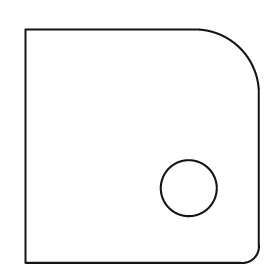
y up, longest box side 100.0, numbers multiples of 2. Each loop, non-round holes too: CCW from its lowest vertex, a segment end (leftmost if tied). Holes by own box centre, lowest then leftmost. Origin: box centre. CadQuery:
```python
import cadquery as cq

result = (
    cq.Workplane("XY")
    .moveTo(-50.0, -50.0)
    .lineTo(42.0, -50.0)
    .threePointArc((48.0, -48.0), (50.0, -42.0))
    .lineTo(50.0, 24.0)
    .threePointArc((42.0, 42.0), (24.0, 50.0))
    .lineTo(-50.0, 50.0)
    .close()
    .moveTo(20.0, -18.0)
    .circle(12.0)
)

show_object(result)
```